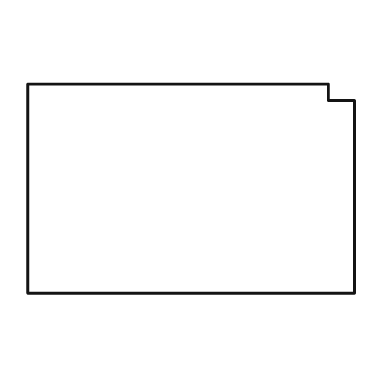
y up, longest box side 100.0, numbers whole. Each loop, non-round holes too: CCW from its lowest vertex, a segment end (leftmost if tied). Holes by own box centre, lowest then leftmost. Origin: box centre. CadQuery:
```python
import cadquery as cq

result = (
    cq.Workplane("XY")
    .moveTo(-50.0, -32.0)
    .lineTo(50.0, -32.0)
    .lineTo(50.0, 27.0)
    .lineTo(42.0, 27.0)
    .lineTo(42.0, 32.0)
    .lineTo(-50.0, 32.0)
    .close()
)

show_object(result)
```